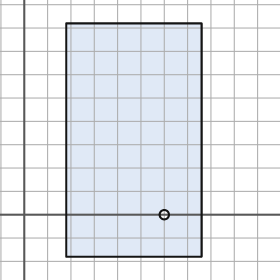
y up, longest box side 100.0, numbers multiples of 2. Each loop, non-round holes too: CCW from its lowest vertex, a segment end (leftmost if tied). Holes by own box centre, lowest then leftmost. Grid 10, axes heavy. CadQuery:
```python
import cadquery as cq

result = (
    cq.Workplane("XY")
    .moveTo(18.0, -18.0)
    .lineTo(76.0, -18.0)
    .lineTo(76.0, 82.0)
    .lineTo(18.0, 82.0)
    .close()
    .moveTo(60.0, 0.0)
    .circle(2.0)
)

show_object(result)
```